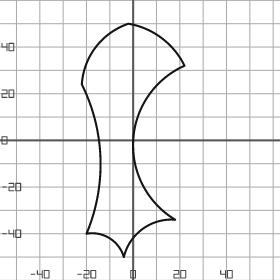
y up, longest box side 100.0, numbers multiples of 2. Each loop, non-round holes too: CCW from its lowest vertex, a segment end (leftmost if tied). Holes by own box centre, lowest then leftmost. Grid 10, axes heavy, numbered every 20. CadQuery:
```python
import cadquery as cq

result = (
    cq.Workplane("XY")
    .moveTo(-4.0, -50.0)
    .threePointArc((4.0, -38.0), (18.0, -34.0))
    .threePointArc((0.0, 0.0), (22.0, 32.0))
    .threePointArc((12.0, 44.0), (-2.0, 50.0))
    .threePointArc((-16.0, 40.0), (-22.0, 24.0))
    .threePointArc((-14.0, -8.0), (-20.0, -40.0))
    .threePointArc((-10.0, -42.0), (-4.0, -50.0))
    .close()
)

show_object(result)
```